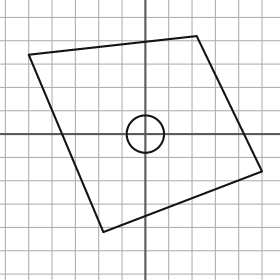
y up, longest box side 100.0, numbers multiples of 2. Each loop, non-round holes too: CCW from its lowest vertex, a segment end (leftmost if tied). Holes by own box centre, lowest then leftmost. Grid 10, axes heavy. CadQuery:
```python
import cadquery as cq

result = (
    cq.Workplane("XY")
    .moveTo(-18.0, -42.0)
    .lineTo(50.0, -16.0)
    .lineTo(22.0, 42.0)
    .lineTo(-50.0, 34.0)
    .close()
    .moveTo(0.0, 0.0)
    .circle(8.0)
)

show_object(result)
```